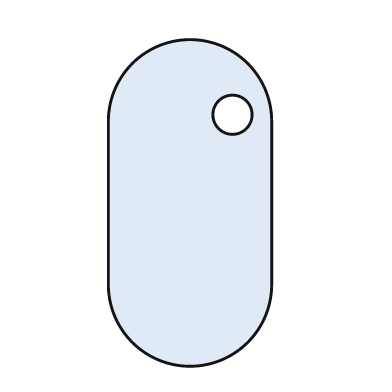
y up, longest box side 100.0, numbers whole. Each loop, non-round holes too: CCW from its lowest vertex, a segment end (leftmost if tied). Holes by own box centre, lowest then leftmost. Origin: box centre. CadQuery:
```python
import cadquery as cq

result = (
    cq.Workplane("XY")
    .moveTo(-25.0, -25.0)
    .threePointArc((0.0, -50.0), (25.0, -25.0))
    .lineTo(25.0, 25.0)
    .threePointArc((0.0, 50.0), (-25.0, 25.0))
    .close()
    .moveTo(13.0, 27.0)
    .circle(6.0)
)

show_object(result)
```